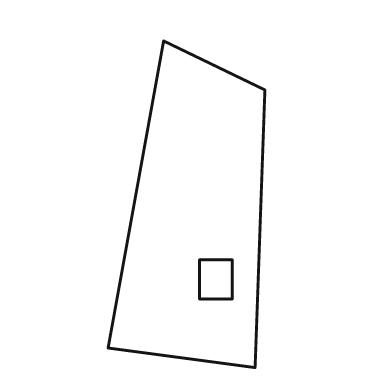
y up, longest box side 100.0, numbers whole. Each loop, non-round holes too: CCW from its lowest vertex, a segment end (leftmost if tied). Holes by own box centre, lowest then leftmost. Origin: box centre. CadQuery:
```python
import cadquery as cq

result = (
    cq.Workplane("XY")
    .moveTo(21.0, -50.0)
    .lineTo(24.0, 35.0)
    .lineTo(-7.0, 50.0)
    .lineTo(-24.0, -44.0)
    .close()
    .moveTo(4.0, -29.0)
    .lineTo(14.0, -29.0)
    .lineTo(14.0, -17.0)
    .lineTo(4.0, -17.0)
    .close()
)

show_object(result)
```